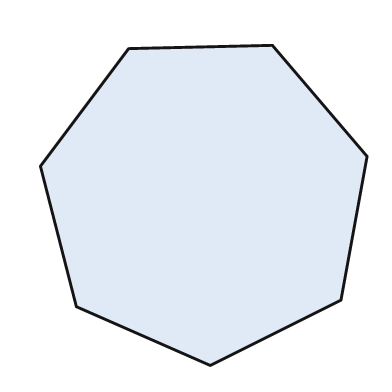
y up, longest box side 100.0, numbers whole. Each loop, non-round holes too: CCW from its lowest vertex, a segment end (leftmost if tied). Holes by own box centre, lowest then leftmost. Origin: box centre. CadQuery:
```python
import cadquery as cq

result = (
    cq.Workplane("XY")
    .moveTo(2.0, -49.0)
    .lineTo(42.0, -29.0)
    .lineTo(50.0, 15.0)
    .lineTo(21.0, 49.0)
    .lineTo(-23.0, 48.0)
    .lineTo(-50.0, 12.0)
    .lineTo(-39.0, -31.0)
    .close()
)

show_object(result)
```